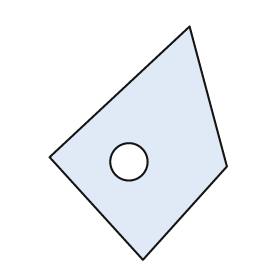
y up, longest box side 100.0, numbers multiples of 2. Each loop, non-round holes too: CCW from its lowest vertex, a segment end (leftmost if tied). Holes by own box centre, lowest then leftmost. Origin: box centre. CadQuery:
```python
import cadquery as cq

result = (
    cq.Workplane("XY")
    .moveTo(2.0, -50.0)
    .lineTo(38.0, -10.0)
    .lineTo(22.0, 50.0)
    .lineTo(-38.0, -6.0)
    .close()
    .moveTo(-4.0, -8.0)
    .circle(8.0)
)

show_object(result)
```